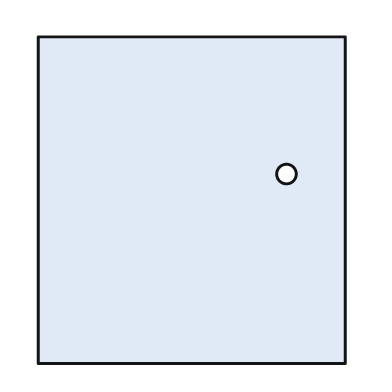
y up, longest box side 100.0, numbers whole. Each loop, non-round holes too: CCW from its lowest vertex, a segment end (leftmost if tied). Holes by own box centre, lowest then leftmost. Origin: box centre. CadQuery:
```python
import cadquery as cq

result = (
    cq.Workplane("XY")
    .moveTo(-47.0, -50.0)
    .lineTo(47.0, -50.0)
    .lineTo(47.0, 50.0)
    .lineTo(-47.0, 50.0)
    .close()
    .moveTo(29.0, 8.0)
    .circle(3.0)
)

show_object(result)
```